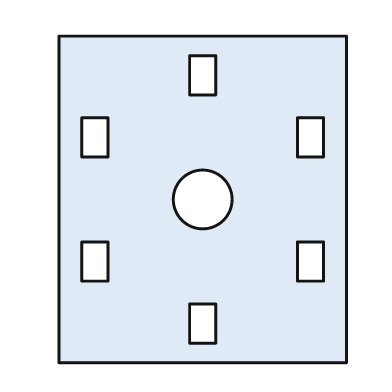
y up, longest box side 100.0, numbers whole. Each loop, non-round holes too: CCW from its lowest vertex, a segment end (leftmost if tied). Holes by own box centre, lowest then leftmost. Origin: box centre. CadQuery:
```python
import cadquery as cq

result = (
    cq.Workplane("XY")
    .moveTo(-44.0, -50.0)
    .lineTo(44.0, -50.0)
    .lineTo(44.0, 50.0)
    .lineTo(-44.0, 50.0)
    .close()
    .moveTo(-4.0, -44.0)
    .lineTo(4.0, -44.0)
    .lineTo(4.0, -32.0)
    .lineTo(-4.0, -32.0)
    .close()
    .moveTo(-37.0, -25.0)
    .lineTo(-29.0, -25.0)
    .lineTo(-29.0, -13.0)
    .lineTo(-37.0, -13.0)
    .close()
    .moveTo(29.0, -25.0)
    .lineTo(37.0, -25.0)
    .lineTo(37.0, -13.0)
    .lineTo(29.0, -13.0)
    .close()
    .moveTo(0.0, 0.0)
    .circle(9.0)
    .moveTo(-37.0, 13.0)
    .lineTo(-29.0, 13.0)
    .lineTo(-29.0, 25.0)
    .lineTo(-37.0, 25.0)
    .close()
    .moveTo(29.0, 13.0)
    .lineTo(37.0, 13.0)
    .lineTo(37.0, 25.0)
    .lineTo(29.0, 25.0)
    .close()
    .moveTo(-4.0, 32.0)
    .lineTo(4.0, 32.0)
    .lineTo(4.0, 44.0)
    .lineTo(-4.0, 44.0)
    .close()
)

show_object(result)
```